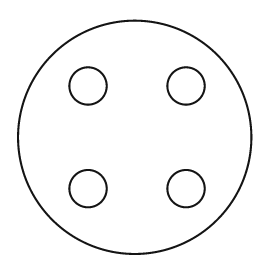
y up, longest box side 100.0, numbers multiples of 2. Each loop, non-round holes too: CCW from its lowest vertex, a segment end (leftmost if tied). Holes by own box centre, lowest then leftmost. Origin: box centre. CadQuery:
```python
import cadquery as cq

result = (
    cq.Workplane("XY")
    .moveTo(0.0, 0.0)
    .circle(50.0)
    .moveTo(-20.0, -22.0)
    .circle(8.0)
    .moveTo(22.0, -22.0)
    .circle(8.0)
    .moveTo(-20.0, 22.0)
    .circle(8.0)
    .moveTo(22.0, 22.0)
    .circle(8.0)
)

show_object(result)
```